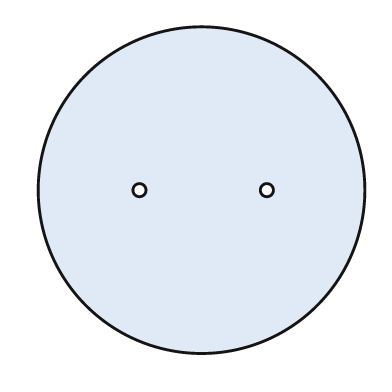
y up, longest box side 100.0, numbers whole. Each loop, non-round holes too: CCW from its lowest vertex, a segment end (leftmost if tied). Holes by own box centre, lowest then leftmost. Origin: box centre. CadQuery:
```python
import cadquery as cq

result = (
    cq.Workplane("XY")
    .moveTo(0.0, 0.0)
    .circle(50.0)
    .moveTo(-19.0, 0.0)
    .circle(2.0)
    .moveTo(20.0, 0.0)
    .circle(2.0)
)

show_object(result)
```